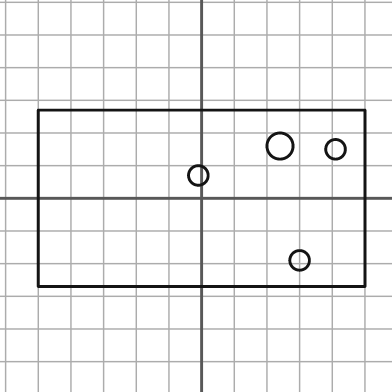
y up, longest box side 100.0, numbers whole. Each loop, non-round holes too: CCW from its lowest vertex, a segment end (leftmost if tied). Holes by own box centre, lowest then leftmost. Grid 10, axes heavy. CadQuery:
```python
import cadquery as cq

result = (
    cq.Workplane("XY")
    .moveTo(-50.0, -27.0)
    .lineTo(50.0, -27.0)
    .lineTo(50.0, 27.0)
    .lineTo(-50.0, 27.0)
    .close()
    .moveTo(30.0, -19.0)
    .circle(3.0)
    .moveTo(-1.0, 7.0)
    .circle(3.0)
    .moveTo(41.0, 15.0)
    .circle(3.0)
    .moveTo(24.0, 16.0)
    .circle(4.0)
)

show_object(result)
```